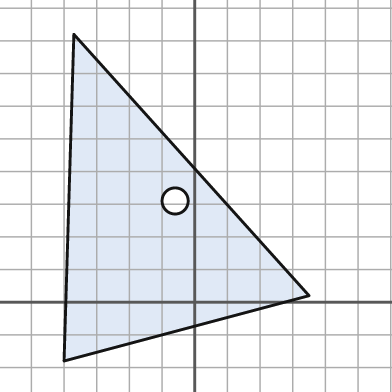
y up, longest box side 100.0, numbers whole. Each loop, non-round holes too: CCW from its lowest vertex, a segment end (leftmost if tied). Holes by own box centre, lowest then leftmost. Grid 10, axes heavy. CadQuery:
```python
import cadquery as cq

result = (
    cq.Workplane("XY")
    .moveTo(-40.0, -18.0)
    .lineTo(35.0, 2.0)
    .lineTo(-37.0, 82.0)
    .close()
    .moveTo(-6.0, 31.0)
    .circle(4.0)
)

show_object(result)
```